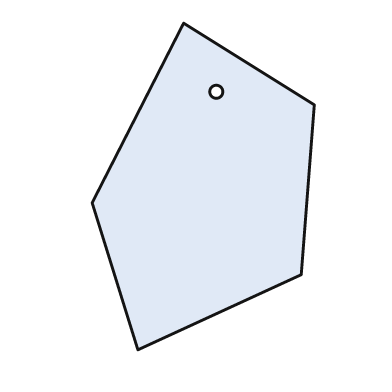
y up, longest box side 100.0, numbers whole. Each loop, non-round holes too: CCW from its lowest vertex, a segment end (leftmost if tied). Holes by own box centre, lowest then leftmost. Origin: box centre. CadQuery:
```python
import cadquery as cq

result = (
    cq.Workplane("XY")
    .moveTo(-20.0, -50.0)
    .lineTo(30.0, -27.0)
    .lineTo(34.0, 25.0)
    .lineTo(-6.0, 50.0)
    .lineTo(-34.0, -5.0)
    .close()
    .moveTo(4.0, 29.0)
    .circle(2.0)
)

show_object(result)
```